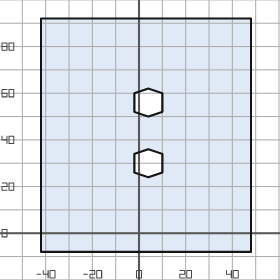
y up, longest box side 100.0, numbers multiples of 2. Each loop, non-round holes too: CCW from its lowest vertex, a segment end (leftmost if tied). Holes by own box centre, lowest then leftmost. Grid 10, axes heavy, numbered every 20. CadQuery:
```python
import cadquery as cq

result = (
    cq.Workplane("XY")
    .moveTo(-42.0, -8.0)
    .lineTo(48.0, -8.0)
    .lineTo(48.0, 92.0)
    .lineTo(-42.0, 92.0)
    .close()
    .moveTo(4.0, 24.0)
    .lineTo(10.0, 26.0)
    .lineTo(10.0, 34.0)
    .lineTo(4.0, 36.0)
    .lineTo(-2.0, 34.0)
    .lineTo(-2.0, 26.0)
    .close()
    .moveTo(4.0, 50.0)
    .lineTo(10.0, 52.0)
    .lineTo(10.0, 60.0)
    .lineTo(4.0, 62.0)
    .lineTo(-2.0, 60.0)
    .lineTo(-2.0, 52.0)
    .close()
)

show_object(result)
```